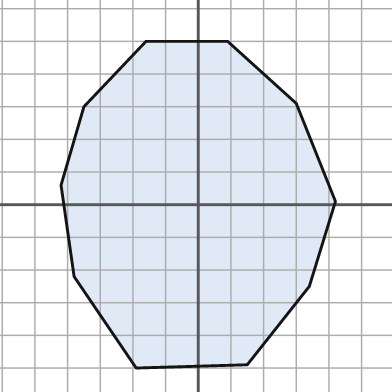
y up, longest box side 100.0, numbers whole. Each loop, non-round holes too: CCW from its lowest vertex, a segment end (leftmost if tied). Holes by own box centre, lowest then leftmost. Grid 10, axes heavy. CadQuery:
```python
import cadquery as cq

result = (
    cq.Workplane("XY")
    .moveTo(-19.0, -50.0)
    .lineTo(15.0, -49.0)
    .lineTo(34.0, -25.0)
    .lineTo(42.0, 1.0)
    .lineTo(30.0, 31.0)
    .lineTo(9.0, 50.0)
    .lineTo(-16.0, 50.0)
    .lineTo(-35.0, 30.0)
    .lineTo(-42.0, 6.0)
    .lineTo(-38.0, -22.0)
    .close()
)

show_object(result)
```